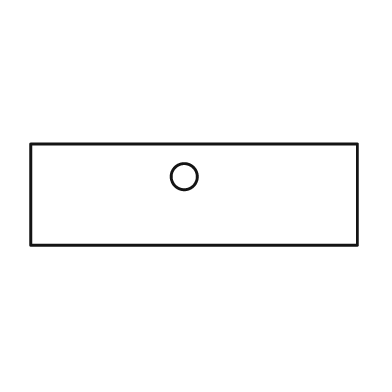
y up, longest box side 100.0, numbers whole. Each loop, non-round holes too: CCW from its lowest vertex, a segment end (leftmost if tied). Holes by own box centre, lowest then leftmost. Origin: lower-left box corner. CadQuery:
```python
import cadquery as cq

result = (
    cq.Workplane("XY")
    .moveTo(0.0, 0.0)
    .lineTo(100.0, 0.0)
    .lineTo(100.0, 31.0)
    .lineTo(0.0, 31.0)
    .close()
    .moveTo(47.0, 21.0)
    .circle(4.0)
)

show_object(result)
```